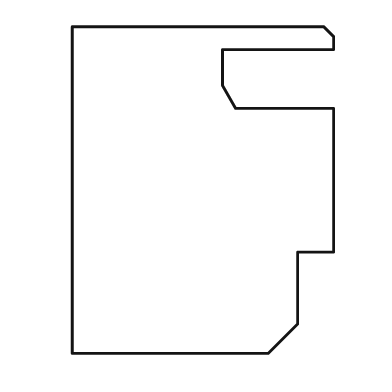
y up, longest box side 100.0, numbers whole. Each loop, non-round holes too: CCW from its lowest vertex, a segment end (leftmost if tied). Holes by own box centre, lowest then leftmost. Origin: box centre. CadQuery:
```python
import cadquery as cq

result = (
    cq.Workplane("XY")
    .moveTo(-40.0, -50.0)
    .lineTo(20.0, -50.0)
    .lineTo(29.0, -41.0)
    .lineTo(29.0, -19.0)
    .lineTo(40.0, -19.0)
    .lineTo(40.0, 25.0)
    .lineTo(10.0, 25.0)
    .lineTo(6.0, 32.0)
    .lineTo(6.0, 43.0)
    .lineTo(40.0, 43.0)
    .lineTo(40.0, 47.0)
    .lineTo(37.0, 50.0)
    .lineTo(-40.0, 50.0)
    .close()
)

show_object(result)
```